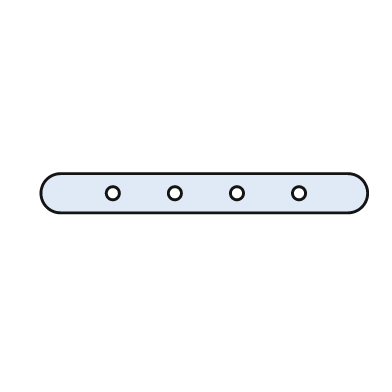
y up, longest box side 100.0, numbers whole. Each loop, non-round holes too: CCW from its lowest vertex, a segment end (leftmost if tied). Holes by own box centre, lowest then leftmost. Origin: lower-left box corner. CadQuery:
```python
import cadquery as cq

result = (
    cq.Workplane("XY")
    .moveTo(6.0, 0.0)
    .lineTo(94.0, 0.0)
    .threePointArc((100.0, 6.0), (94.0, 12.0))
    .lineTo(6.0, 12.0)
    .threePointArc((0.0, 6.0), (6.0, 0.0))
    .close()
    .moveTo(22.0, 6.0)
    .circle(2.0)
    .moveTo(41.0, 6.0)
    .circle(2.0)
    .moveTo(60.0, 6.0)
    .circle(2.0)
    .moveTo(79.0, 6.0)
    .circle(2.0)
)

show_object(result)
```